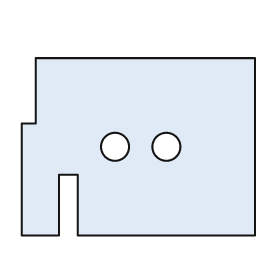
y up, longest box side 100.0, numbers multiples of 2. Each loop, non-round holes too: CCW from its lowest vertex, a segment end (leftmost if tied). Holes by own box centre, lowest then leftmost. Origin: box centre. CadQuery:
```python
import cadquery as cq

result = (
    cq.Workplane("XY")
    .moveTo(-50.0, -38.0)
    .lineTo(-34.0, -38.0)
    .lineTo(-34.0, -12.0)
    .lineTo(-26.0, -12.0)
    .lineTo(-26.0, -38.0)
    .lineTo(50.0, -38.0)
    .lineTo(50.0, 38.0)
    .lineTo(-44.0, 38.0)
    .lineTo(-44.0, 10.0)
    .lineTo(-50.0, 10.0)
    .close()
    .moveTo(-10.0, 0.0)
    .circle(6.0)
    .moveTo(12.0, 0.0)
    .circle(6.0)
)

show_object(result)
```